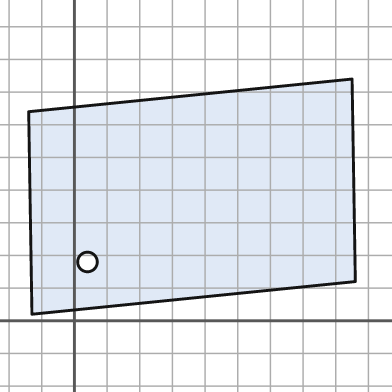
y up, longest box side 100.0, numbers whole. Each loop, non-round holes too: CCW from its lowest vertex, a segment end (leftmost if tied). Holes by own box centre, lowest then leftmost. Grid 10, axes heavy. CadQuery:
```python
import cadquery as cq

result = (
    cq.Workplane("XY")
    .moveTo(-13.0, 2.0)
    .lineTo(86.0, 12.0)
    .lineTo(85.0, 74.0)
    .lineTo(-14.0, 64.0)
    .close()
    .moveTo(4.0, 18.0)
    .circle(3.0)
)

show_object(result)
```